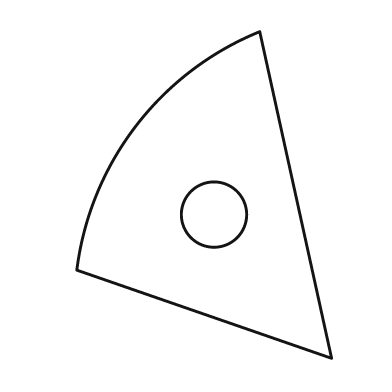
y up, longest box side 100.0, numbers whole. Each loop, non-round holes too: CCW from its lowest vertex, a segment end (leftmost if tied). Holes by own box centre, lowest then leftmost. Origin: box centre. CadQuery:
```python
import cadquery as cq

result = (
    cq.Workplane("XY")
    .moveTo(39.0, -50.0)
    .lineTo(17.0, 50.0)
    .threePointArc((-21.0, 21.0), (-39.0, -23.0))
    .close()
    .moveTo(3.0, -6.0)
    .circle(10.0)
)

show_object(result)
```